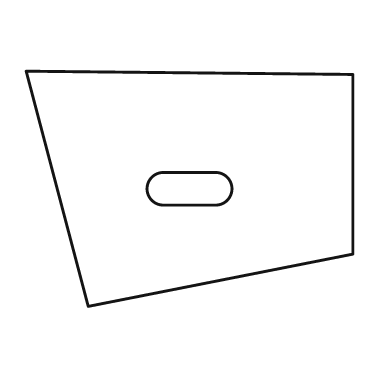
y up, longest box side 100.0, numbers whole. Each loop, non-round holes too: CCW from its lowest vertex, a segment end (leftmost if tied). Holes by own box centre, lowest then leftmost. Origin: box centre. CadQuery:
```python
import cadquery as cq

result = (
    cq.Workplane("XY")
    .moveTo(-31.0, -36.0)
    .lineTo(50.0, -20.0)
    .lineTo(50.0, 35.0)
    .lineTo(-50.0, 36.0)
    .close()
    .moveTo(-8.0, -5.0)
    .lineTo(8.0, -5.0)
    .threePointArc((13.0, 0.0), (8.0, 5.0))
    .lineTo(-8.0, 5.0)
    .threePointArc((-13.0, 0.0), (-8.0, -5.0))
    .close()
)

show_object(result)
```